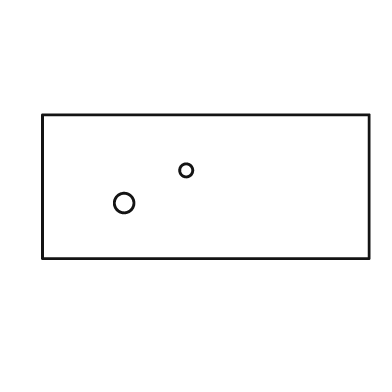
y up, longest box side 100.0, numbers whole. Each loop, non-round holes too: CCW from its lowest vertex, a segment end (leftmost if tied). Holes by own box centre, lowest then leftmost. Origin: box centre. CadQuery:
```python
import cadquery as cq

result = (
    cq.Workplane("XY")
    .moveTo(-50.0, -22.0)
    .lineTo(50.0, -22.0)
    .lineTo(50.0, 22.0)
    .lineTo(-50.0, 22.0)
    .close()
    .moveTo(-25.0, -5.0)
    .circle(3.0)
    .moveTo(-6.0, 5.0)
    .circle(2.0)
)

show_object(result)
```